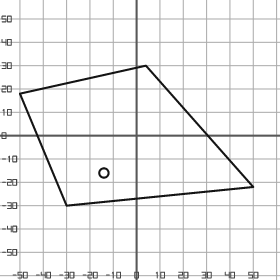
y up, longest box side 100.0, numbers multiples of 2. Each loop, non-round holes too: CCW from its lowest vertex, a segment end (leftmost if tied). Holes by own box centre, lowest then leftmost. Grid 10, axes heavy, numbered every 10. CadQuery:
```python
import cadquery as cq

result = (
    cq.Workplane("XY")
    .moveTo(-30.0, -30.0)
    .lineTo(50.0, -22.0)
    .lineTo(4.0, 30.0)
    .lineTo(-50.0, 18.0)
    .close()
    .moveTo(-14.0, -16.0)
    .circle(2.0)
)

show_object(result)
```